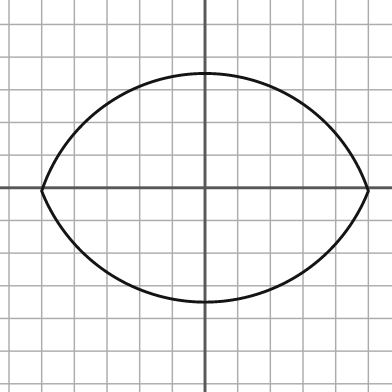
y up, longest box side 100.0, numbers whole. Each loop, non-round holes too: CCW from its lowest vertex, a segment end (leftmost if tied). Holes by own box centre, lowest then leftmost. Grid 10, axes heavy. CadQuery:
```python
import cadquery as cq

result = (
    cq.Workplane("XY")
    .moveTo(-50.0, -1.0)
    .threePointArc((0.0, -35.0), (50.0, -1.0))
    .threePointArc((0.0, 35.0), (-50.0, -1.0))
    .close()
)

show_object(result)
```